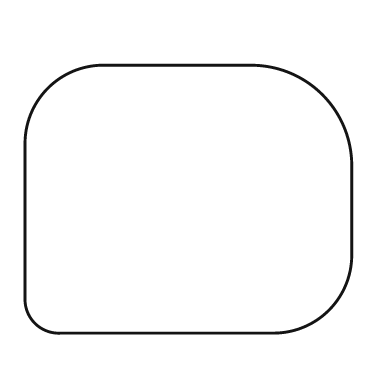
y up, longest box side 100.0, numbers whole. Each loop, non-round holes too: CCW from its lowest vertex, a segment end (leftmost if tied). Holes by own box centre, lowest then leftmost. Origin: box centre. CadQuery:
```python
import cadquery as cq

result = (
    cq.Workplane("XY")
    .moveTo(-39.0, -41.0)
    .lineTo(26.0, -41.0)
    .threePointArc((43.0, -34.0), (50.0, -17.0))
    .lineTo(50.0, 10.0)
    .threePointArc((41.0, 32.0), (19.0, 41.0))
    .lineTo(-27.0, 41.0)
    .threePointArc((-43.0, 34.0), (-50.0, 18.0))
    .lineTo(-50.0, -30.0)
    .threePointArc((-47.0, -38.0), (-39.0, -41.0))
    .close()
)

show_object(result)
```